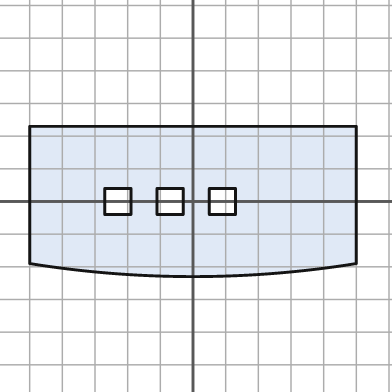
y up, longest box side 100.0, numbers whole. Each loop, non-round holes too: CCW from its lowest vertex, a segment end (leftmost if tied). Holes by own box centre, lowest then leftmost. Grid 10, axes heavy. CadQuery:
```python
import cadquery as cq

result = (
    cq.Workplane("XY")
    .moveTo(-50.0, -19.0)
    .threePointArc((0.0, -23.0), (50.0, -19.0))
    .lineTo(50.0, 23.0)
    .lineTo(-50.0, 23.0)
    .close()
    .moveTo(-27.0, -4.0)
    .lineTo(-19.0, -4.0)
    .lineTo(-19.0, 4.0)
    .lineTo(-27.0, 4.0)
    .close()
    .moveTo(-11.0, -4.0)
    .lineTo(-3.0, -4.0)
    .lineTo(-3.0, 4.0)
    .lineTo(-11.0, 4.0)
    .close()
    .moveTo(5.0, -4.0)
    .lineTo(13.0, -4.0)
    .lineTo(13.0, 4.0)
    .lineTo(5.0, 4.0)
    .close()
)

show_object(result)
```